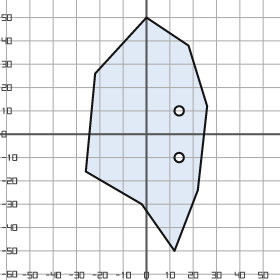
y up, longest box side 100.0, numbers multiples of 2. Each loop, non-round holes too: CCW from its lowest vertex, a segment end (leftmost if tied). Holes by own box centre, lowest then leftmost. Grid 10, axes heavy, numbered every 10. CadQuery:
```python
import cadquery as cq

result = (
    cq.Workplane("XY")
    .moveTo(12.0, -50.0)
    .lineTo(22.0, -24.0)
    .lineTo(26.0, 12.0)
    .lineTo(18.0, 38.0)
    .lineTo(0.0, 50.0)
    .lineTo(-22.0, 26.0)
    .lineTo(-26.0, -16.0)
    .lineTo(-2.0, -30.0)
    .close()
    .moveTo(14.0, -10.0)
    .circle(2.0)
    .moveTo(14.0, 10.0)
    .circle(2.0)
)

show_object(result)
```